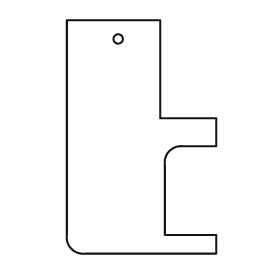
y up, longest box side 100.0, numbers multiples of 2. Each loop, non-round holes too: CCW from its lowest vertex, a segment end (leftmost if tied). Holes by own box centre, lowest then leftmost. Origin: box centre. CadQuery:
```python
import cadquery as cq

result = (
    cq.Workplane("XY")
    .moveTo(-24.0, -50.0)
    .lineTo(32.0, -50.0)
    .lineTo(32.0, -42.0)
    .lineTo(10.0, -42.0)
    .lineTo(10.0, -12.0)
    .threePointArc((12.0, -6.0), (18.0, -4.0))
    .lineTo(32.0, -4.0)
    .lineTo(32.0, 8.0)
    .lineTo(8.0, 8.0)
    .lineTo(8.0, 50.0)
    .lineTo(-32.0, 50.0)
    .lineTo(-32.0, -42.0)
    .threePointArc((-30.0, -48.0), (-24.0, -50.0))
    .close()
    .moveTo(-10.0, 42.0)
    .circle(2.0)
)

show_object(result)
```